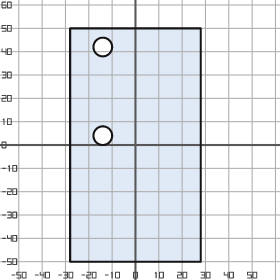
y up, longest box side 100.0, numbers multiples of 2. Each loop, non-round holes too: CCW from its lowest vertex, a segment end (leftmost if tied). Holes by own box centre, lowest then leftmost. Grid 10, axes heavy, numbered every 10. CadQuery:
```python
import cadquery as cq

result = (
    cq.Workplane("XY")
    .moveTo(-28.0, -50.0)
    .lineTo(28.0, -50.0)
    .lineTo(28.0, 50.0)
    .lineTo(-28.0, 50.0)
    .close()
    .moveTo(-14.0, 4.0)
    .circle(4.0)
    .moveTo(-14.0, 42.0)
    .circle(4.0)
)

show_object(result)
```